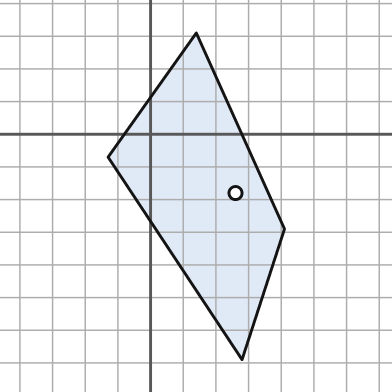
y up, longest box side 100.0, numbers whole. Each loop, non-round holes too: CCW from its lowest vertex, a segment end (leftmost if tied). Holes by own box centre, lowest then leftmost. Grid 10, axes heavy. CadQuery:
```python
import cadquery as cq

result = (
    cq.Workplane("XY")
    .moveTo(28.0, -69.0)
    .lineTo(41.0, -29.0)
    .lineTo(14.0, 31.0)
    .lineTo(-13.0, -7.0)
    .close()
    .moveTo(26.0, -18.0)
    .circle(2.0)
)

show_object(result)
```